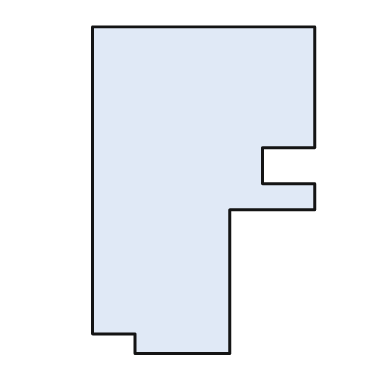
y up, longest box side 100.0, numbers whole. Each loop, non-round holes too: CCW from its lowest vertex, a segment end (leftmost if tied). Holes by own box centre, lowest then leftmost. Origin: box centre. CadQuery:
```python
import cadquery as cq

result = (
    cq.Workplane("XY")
    .moveTo(-21.0, -50.0)
    .lineTo(8.0, -50.0)
    .lineTo(8.0, -6.0)
    .lineTo(34.0, -6.0)
    .lineTo(34.0, 2.0)
    .lineTo(18.0, 2.0)
    .lineTo(18.0, 13.0)
    .lineTo(34.0, 13.0)
    .lineTo(34.0, 50.0)
    .lineTo(-34.0, 50.0)
    .lineTo(-34.0, -44.0)
    .lineTo(-21.0, -44.0)
    .close()
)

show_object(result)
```